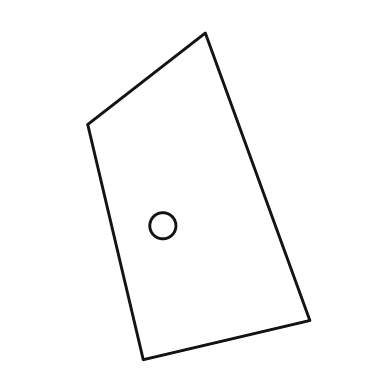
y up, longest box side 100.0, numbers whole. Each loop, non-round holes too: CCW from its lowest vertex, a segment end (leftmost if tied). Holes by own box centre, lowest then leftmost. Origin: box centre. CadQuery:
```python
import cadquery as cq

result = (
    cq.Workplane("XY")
    .moveTo(-17.0, -50.0)
    .lineTo(34.0, -38.0)
    .lineTo(2.0, 50.0)
    .lineTo(-34.0, 22.0)
    .close()
    .moveTo(-11.0, -9.0)
    .circle(4.0)
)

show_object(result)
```